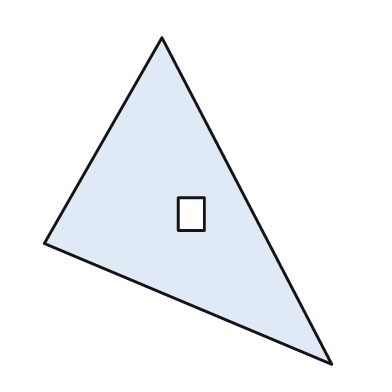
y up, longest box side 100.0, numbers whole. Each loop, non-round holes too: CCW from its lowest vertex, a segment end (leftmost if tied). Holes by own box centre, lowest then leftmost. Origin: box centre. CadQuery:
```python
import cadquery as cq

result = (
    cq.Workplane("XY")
    .moveTo(44.0, -50.0)
    .lineTo(-8.0, 50.0)
    .lineTo(-44.0, -13.0)
    .close()
    .moveTo(-3.0, -9.0)
    .lineTo(5.0, -9.0)
    .lineTo(5.0, 1.0)
    .lineTo(-3.0, 1.0)
    .close()
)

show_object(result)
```